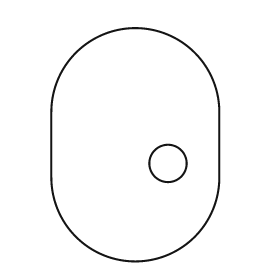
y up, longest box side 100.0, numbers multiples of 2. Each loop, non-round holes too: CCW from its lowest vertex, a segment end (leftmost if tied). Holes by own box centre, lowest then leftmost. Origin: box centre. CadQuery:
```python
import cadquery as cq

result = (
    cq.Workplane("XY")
    .moveTo(-36.0, -14.0)
    .threePointArc((0.0, -50.0), (36.0, -14.0))
    .lineTo(36.0, 14.0)
    .threePointArc((0.0, 50.0), (-36.0, 14.0))
    .close()
    .moveTo(14.0, -8.0)
    .circle(8.0)
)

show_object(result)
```